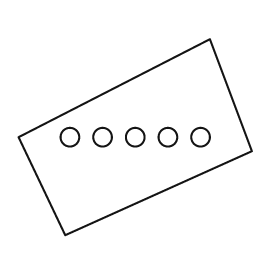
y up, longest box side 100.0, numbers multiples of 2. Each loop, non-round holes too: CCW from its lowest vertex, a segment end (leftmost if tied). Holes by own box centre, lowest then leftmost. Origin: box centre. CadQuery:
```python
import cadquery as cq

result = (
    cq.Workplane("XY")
    .moveTo(-30.0, -42.0)
    .lineTo(50.0, -6.0)
    .lineTo(32.0, 42.0)
    .lineTo(-50.0, 0.0)
    .close()
    .moveTo(-28.0, 0.0)
    .circle(4.0)
    .moveTo(-14.0, 0.0)
    .circle(4.0)
    .moveTo(0.0, 0.0)
    .circle(4.0)
    .moveTo(14.0, 0.0)
    .circle(4.0)
    .moveTo(28.0, 0.0)
    .circle(4.0)
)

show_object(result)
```